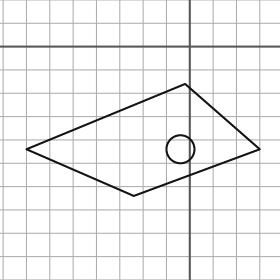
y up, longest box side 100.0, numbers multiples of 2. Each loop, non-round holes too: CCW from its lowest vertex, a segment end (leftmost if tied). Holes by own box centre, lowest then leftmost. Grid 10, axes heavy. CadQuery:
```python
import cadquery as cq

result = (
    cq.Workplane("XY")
    .moveTo(-24.0, -64.0)
    .lineTo(30.0, -44.0)
    .lineTo(-2.0, -16.0)
    .lineTo(-70.0, -44.0)
    .close()
    .moveTo(-4.0, -44.0)
    .circle(6.0)
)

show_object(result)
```